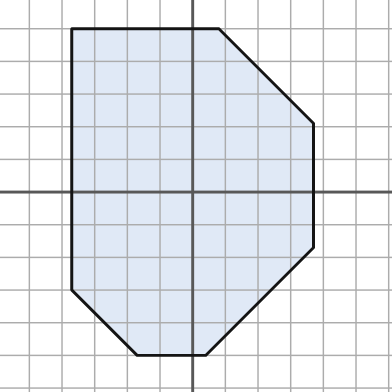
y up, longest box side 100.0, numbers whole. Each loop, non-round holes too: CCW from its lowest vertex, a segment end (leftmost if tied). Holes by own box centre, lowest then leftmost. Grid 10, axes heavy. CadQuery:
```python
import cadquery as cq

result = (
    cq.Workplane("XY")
    .moveTo(-17.0, -50.0)
    .lineTo(4.0, -50.0)
    .lineTo(37.0, -17.0)
    .lineTo(37.0, 21.0)
    .lineTo(8.0, 50.0)
    .lineTo(-37.0, 50.0)
    .lineTo(-37.0, -30.0)
    .close()
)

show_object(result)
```